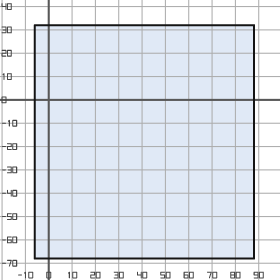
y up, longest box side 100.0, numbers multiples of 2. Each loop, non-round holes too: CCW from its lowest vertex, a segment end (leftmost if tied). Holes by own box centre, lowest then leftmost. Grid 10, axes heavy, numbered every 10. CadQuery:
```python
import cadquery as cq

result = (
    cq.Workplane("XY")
    .moveTo(-6.0, -68.0)
    .lineTo(88.0, -68.0)
    .lineTo(88.0, 32.0)
    .lineTo(-6.0, 32.0)
    .close()
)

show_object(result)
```